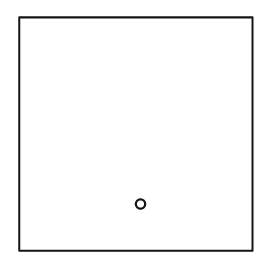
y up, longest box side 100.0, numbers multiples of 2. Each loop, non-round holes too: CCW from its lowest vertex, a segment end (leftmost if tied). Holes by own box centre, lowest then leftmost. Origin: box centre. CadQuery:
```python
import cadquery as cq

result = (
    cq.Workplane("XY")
    .moveTo(-50.0, -50.0)
    .lineTo(50.0, -50.0)
    .lineTo(50.0, 50.0)
    .lineTo(-50.0, 50.0)
    .close()
    .moveTo(2.0, -30.0)
    .circle(2.0)
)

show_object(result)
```